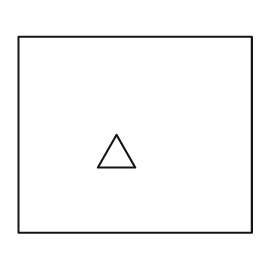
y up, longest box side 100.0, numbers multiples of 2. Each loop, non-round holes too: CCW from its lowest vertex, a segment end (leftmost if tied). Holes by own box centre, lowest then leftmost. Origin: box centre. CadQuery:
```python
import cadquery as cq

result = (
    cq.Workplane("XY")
    .moveTo(-50.0, -42.0)
    .lineTo(50.0, -42.0)
    .lineTo(50.0, 42.0)
    .lineTo(-50.0, 42.0)
    .close()
    .moveTo(-16.0, -14.0)
    .lineTo(0.0, -14.0)
    .lineTo(-8.0, 0.0)
    .close()
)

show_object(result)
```